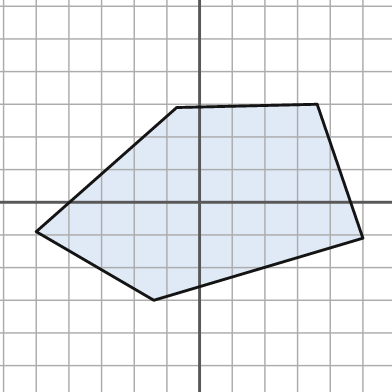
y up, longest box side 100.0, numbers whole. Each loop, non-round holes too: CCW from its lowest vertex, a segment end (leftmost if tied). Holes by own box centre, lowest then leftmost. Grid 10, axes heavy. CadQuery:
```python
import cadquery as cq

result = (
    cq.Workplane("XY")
    .moveTo(-14.0, -30.0)
    .lineTo(50.0, -11.0)
    .lineTo(36.0, 30.0)
    .lineTo(-7.0, 29.0)
    .lineTo(-50.0, -9.0)
    .close()
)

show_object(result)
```